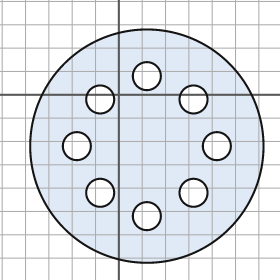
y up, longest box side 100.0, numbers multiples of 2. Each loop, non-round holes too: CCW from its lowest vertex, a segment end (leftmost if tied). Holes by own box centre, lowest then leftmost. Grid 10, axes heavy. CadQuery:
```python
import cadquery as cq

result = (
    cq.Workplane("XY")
    .moveTo(12.0, -22.0)
    .circle(50.0)
    .moveTo(12.0, -52.0)
    .circle(6.0)
    .moveTo(-8.0, -42.0)
    .circle(6.0)
    .moveTo(32.0, -42.0)
    .circle(6.0)
    .moveTo(-18.0, -22.0)
    .circle(6.0)
    .moveTo(42.0, -22.0)
    .circle(6.0)
    .moveTo(-8.0, -2.0)
    .circle(6.0)
    .moveTo(32.0, -2.0)
    .circle(6.0)
    .moveTo(12.0, 8.0)
    .circle(6.0)
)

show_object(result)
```